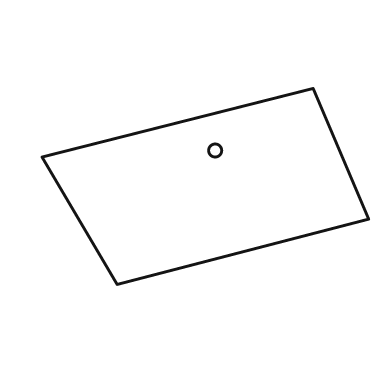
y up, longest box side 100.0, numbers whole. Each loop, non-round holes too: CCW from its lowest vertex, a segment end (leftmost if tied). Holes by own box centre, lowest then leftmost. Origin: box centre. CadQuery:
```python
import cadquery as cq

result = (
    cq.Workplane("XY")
    .moveTo(-27.0, -30.0)
    .lineTo(50.0, -10.0)
    .lineTo(33.0, 30.0)
    .lineTo(-50.0, 9.0)
    .close()
    .moveTo(3.0, 11.0)
    .circle(2.0)
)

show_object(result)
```